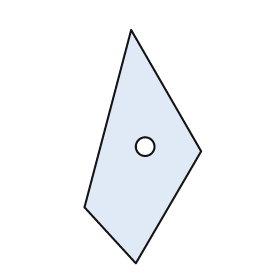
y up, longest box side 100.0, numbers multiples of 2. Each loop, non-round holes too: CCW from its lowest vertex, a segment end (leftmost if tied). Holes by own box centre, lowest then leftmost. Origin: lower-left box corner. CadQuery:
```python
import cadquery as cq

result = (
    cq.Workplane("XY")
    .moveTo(22.0, 0.0)
    .lineTo(50.0, 48.0)
    .lineTo(20.0, 100.0)
    .lineTo(0.0, 24.0)
    .close()
    .moveTo(26.0, 50.0)
    .circle(4.0)
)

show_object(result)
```